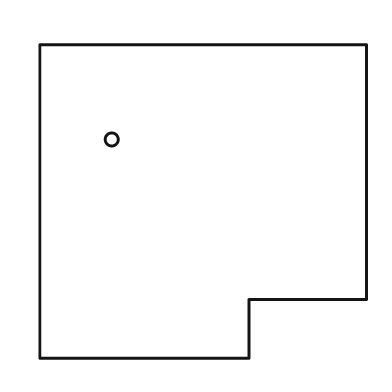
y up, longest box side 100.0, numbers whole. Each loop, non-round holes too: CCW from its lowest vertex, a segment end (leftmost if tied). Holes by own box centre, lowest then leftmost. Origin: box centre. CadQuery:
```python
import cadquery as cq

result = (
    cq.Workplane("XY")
    .moveTo(-50.0, -48.0)
    .lineTo(14.0, -48.0)
    .lineTo(14.0, -30.0)
    .lineTo(50.0, -30.0)
    .lineTo(50.0, 48.0)
    .lineTo(-50.0, 48.0)
    .close()
    .moveTo(-28.0, 19.0)
    .circle(2.0)
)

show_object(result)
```